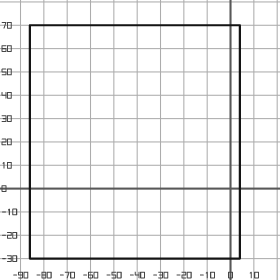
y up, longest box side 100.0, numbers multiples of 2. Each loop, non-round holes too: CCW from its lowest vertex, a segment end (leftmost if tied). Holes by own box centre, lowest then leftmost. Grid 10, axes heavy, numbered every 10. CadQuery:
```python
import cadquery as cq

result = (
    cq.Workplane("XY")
    .moveTo(-86.0, -30.0)
    .lineTo(4.0, -30.0)
    .lineTo(4.0, 70.0)
    .lineTo(-86.0, 70.0)
    .close()
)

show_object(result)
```